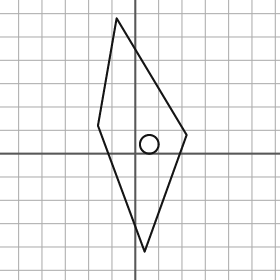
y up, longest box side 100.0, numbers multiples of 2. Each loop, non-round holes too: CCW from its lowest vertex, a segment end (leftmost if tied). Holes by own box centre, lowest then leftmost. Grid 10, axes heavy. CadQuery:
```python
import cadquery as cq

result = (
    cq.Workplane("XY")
    .moveTo(4.0, -42.0)
    .lineTo(22.0, 8.0)
    .lineTo(-8.0, 58.0)
    .lineTo(-16.0, 12.0)
    .close()
    .moveTo(6.0, 4.0)
    .circle(4.0)
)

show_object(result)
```